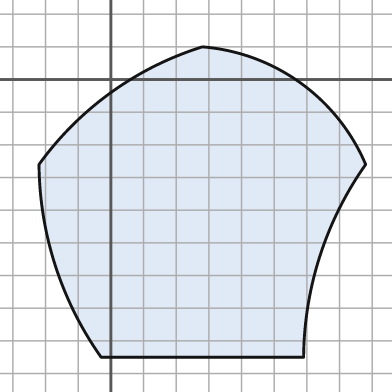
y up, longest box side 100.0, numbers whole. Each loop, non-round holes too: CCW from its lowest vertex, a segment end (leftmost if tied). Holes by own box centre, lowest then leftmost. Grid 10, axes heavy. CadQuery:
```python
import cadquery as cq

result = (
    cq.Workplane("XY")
    .moveTo(-3.0, -85.0)
    .lineTo(59.0, -85.0)
    .threePointArc((64.0, -54.0), (78.0, -26.0))
    .threePointArc((58.0, -1.0), (28.0, 10.0))
    .threePointArc((0.0, -4.0), (-22.0, -26.0))
    .threePointArc((-17.0, -57.0), (-3.0, -85.0))
    .close()
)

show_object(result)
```